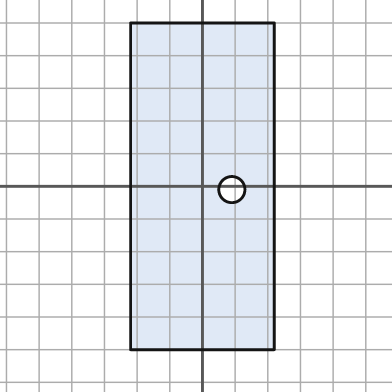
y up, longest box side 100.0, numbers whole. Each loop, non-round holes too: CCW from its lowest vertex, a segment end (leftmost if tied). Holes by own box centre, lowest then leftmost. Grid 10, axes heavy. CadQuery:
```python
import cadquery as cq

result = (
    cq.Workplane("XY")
    .moveTo(-22.0, -50.0)
    .lineTo(22.0, -50.0)
    .lineTo(22.0, 50.0)
    .lineTo(-22.0, 50.0)
    .close()
    .moveTo(9.0, -1.0)
    .circle(4.0)
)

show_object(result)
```